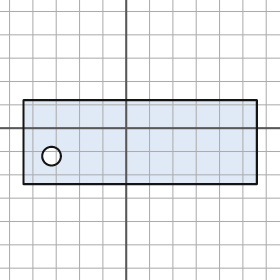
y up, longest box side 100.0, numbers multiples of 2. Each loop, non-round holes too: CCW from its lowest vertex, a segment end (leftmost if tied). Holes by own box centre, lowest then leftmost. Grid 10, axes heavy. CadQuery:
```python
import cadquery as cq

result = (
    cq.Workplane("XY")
    .moveTo(-44.0, -24.0)
    .lineTo(56.0, -24.0)
    .lineTo(56.0, 12.0)
    .lineTo(-44.0, 12.0)
    .close()
    .moveTo(-32.0, -12.0)
    .circle(4.0)
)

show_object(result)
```